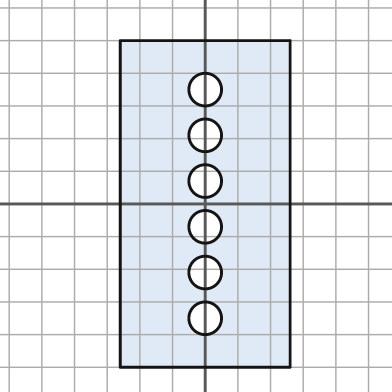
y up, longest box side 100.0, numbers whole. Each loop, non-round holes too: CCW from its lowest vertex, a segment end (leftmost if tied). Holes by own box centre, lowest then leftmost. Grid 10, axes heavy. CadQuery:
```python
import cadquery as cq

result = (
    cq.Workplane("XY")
    .moveTo(-26.0, -50.0)
    .lineTo(26.0, -50.0)
    .lineTo(26.0, 50.0)
    .lineTo(-26.0, 50.0)
    .close()
    .moveTo(0.0, -35.0)
    .circle(5.0)
    .moveTo(0.0, -21.0)
    .circle(5.0)
    .moveTo(0.0, -7.0)
    .circle(5.0)
    .moveTo(0.0, 7.0)
    .circle(5.0)
    .moveTo(0.0, 21.0)
    .circle(5.0)
    .moveTo(0.0, 35.0)
    .circle(5.0)
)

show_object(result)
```